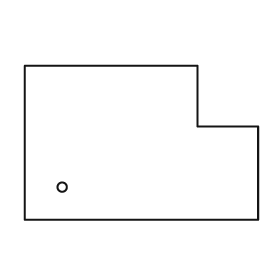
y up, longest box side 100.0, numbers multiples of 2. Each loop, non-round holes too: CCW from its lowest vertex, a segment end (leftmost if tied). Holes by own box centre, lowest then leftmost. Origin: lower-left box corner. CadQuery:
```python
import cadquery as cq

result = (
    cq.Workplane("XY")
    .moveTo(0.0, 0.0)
    .lineTo(100.0, 0.0)
    .lineTo(100.0, 40.0)
    .lineTo(74.0, 40.0)
    .lineTo(74.0, 66.0)
    .lineTo(0.0, 66.0)
    .close()
    .moveTo(16.0, 14.0)
    .circle(2.0)
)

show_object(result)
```